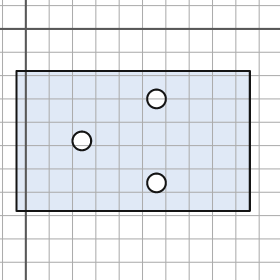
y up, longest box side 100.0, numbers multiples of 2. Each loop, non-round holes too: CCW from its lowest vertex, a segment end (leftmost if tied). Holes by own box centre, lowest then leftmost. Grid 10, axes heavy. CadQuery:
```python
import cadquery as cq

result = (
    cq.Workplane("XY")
    .moveTo(-4.0, -78.0)
    .lineTo(96.0, -78.0)
    .lineTo(96.0, -18.0)
    .lineTo(-4.0, -18.0)
    .close()
    .moveTo(56.0, -66.0)
    .circle(4.0)
    .moveTo(24.0, -48.0)
    .circle(4.0)
    .moveTo(56.0, -30.0)
    .circle(4.0)
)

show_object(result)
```